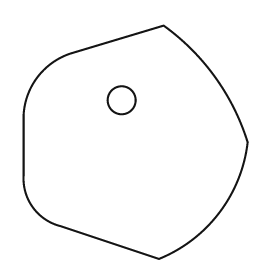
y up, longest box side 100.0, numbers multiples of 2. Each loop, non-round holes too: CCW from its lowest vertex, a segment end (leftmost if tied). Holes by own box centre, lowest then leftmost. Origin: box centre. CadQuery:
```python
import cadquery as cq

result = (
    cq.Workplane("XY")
    .moveTo(10.0, -50.0)
    .threePointArc((36.0, -30.0), (48.0, 0.0))
    .threePointArc((34.0, 28.0), (12.0, 50.0))
    .lineTo(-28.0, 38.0)
    .threePointArc((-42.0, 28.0), (-48.0, 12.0))
    .lineTo(-48.0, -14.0)
    .threePointArc((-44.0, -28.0), (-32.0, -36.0))
    .close()
    .moveTo(-6.0, 18.0)
    .circle(6.0)
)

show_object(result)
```